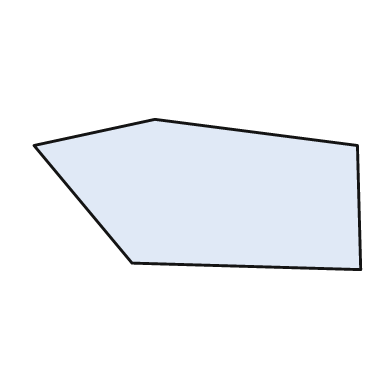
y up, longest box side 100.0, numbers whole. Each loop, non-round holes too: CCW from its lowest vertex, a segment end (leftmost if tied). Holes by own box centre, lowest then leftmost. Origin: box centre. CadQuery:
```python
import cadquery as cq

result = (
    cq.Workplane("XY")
    .moveTo(50.0, -23.0)
    .lineTo(49.0, 15.0)
    .lineTo(-13.0, 23.0)
    .lineTo(-50.0, 15.0)
    .lineTo(-20.0, -21.0)
    .close()
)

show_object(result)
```